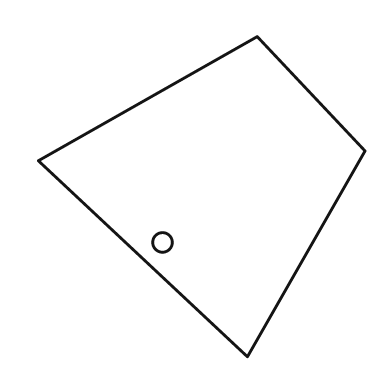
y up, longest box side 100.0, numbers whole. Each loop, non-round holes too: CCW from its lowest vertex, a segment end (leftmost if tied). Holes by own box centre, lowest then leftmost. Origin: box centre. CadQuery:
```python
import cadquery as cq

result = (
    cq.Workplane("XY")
    .moveTo(14.0, -49.0)
    .lineTo(50.0, 14.0)
    .lineTo(17.0, 49.0)
    .lineTo(-50.0, 11.0)
    .close()
    .moveTo(-12.0, -14.0)
    .circle(3.0)
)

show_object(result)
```